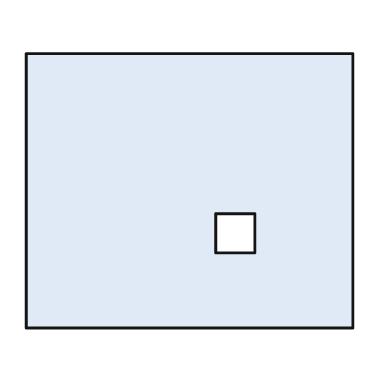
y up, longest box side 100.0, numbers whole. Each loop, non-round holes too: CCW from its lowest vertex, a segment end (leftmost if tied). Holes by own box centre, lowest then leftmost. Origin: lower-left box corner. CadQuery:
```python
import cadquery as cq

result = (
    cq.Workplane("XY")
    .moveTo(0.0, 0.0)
    .lineTo(100.0, 0.0)
    .lineTo(100.0, 84.0)
    .lineTo(0.0, 84.0)
    .close()
    .moveTo(58.0, 23.0)
    .lineTo(70.0, 23.0)
    .lineTo(70.0, 35.0)
    .lineTo(58.0, 35.0)
    .close()
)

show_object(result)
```